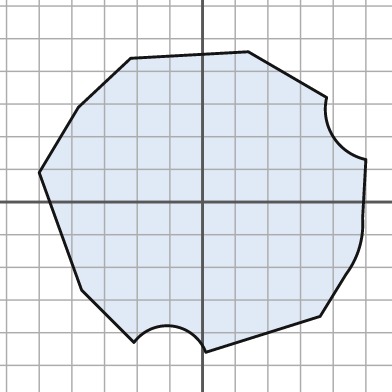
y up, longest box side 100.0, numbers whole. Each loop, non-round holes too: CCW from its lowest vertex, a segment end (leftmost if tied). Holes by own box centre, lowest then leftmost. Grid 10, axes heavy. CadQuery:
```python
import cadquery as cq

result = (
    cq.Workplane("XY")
    .moveTo(1.0, -46.0)
    .lineTo(36.0, -35.0)
    .lineTo(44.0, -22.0)
    .threePointArc((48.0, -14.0), (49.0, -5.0))
    .lineTo(50.0, 13.0)
    .threePointArc((40.0, 20.0), (38.0, 32.0))
    .lineTo(14.0, 46.0)
    .lineTo(-22.0, 44.0)
    .lineTo(-38.0, 29.0)
    .lineTo(-50.0, 9.0)
    .lineTo(-37.0, -27.0)
    .lineTo(-21.0, -43.0)
    .threePointArc((-9.0, -38.0), (1.0, -46.0))
    .close()
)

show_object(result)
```